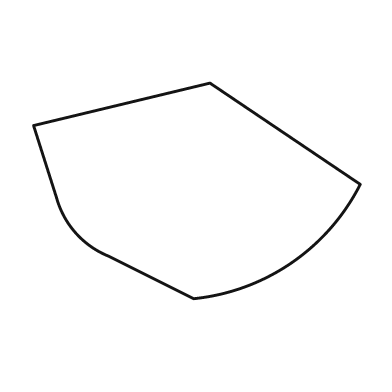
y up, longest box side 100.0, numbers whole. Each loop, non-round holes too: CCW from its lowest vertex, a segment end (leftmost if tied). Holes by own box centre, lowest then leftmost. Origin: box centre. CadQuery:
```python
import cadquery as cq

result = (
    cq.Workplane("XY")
    .moveTo(-1.0, -33.0)
    .threePointArc((29.0, -22.0), (50.0, 2.0))
    .lineTo(4.0, 33.0)
    .lineTo(-50.0, 20.0)
    .lineTo(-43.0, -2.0)
    .threePointArc((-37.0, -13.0), (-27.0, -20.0))
    .close()
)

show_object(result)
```